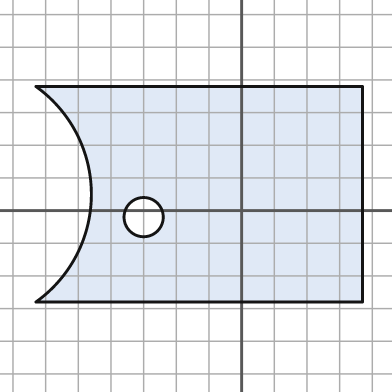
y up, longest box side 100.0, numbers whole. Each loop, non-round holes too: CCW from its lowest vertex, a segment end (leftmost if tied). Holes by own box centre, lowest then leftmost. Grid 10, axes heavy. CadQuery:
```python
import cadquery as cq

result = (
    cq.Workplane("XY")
    .moveTo(-63.0, -28.0)
    .lineTo(37.0, -28.0)
    .lineTo(37.0, 38.0)
    .lineTo(-63.0, 38.0)
    .threePointArc((-46.0, 5.0), (-63.0, -28.0))
    .close()
    .moveTo(-30.0, -2.0)
    .circle(6.0)
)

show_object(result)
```